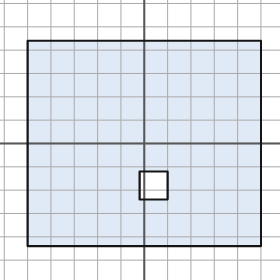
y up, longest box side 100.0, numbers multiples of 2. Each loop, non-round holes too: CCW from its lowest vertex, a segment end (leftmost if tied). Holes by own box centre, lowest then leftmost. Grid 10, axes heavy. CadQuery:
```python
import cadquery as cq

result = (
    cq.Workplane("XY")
    .moveTo(-50.0, -44.0)
    .lineTo(50.0, -44.0)
    .lineTo(50.0, 44.0)
    .lineTo(-50.0, 44.0)
    .close()
    .moveTo(-2.0, -24.0)
    .lineTo(10.0, -24.0)
    .lineTo(10.0, -12.0)
    .lineTo(-2.0, -12.0)
    .close()
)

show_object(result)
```